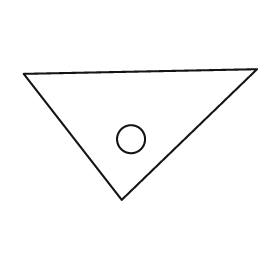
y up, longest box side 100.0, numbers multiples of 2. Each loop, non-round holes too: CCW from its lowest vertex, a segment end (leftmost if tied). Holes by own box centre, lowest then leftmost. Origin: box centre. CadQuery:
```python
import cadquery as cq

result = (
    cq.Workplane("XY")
    .moveTo(-8.0, -28.0)
    .lineTo(50.0, 28.0)
    .lineTo(-50.0, 26.0)
    .close()
    .moveTo(-4.0, -2.0)
    .circle(6.0)
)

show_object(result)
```